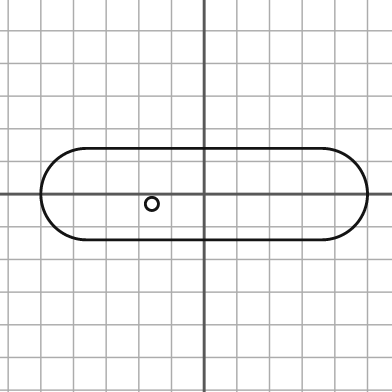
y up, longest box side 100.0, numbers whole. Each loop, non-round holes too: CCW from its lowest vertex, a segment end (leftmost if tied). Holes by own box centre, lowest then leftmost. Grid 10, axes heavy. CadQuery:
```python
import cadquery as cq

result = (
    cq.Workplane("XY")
    .moveTo(-36.0, -14.0)
    .lineTo(36.0, -14.0)
    .threePointArc((50.0, 0.0), (36.0, 14.0))
    .lineTo(-36.0, 14.0)
    .threePointArc((-50.0, 0.0), (-36.0, -14.0))
    .close()
    .moveTo(-16.0, -3.0)
    .circle(2.0)
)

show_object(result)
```